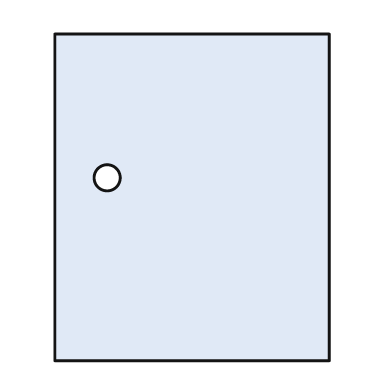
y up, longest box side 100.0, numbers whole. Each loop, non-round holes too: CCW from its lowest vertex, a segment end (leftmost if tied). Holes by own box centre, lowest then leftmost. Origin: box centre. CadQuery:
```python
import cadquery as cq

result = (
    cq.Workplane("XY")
    .moveTo(-42.0, -50.0)
    .lineTo(42.0, -50.0)
    .lineTo(42.0, 50.0)
    .lineTo(-42.0, 50.0)
    .close()
    .moveTo(-26.0, 6.0)
    .circle(4.0)
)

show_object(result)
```